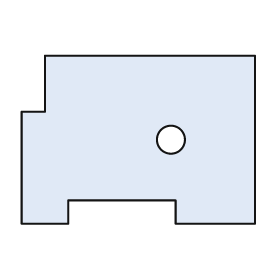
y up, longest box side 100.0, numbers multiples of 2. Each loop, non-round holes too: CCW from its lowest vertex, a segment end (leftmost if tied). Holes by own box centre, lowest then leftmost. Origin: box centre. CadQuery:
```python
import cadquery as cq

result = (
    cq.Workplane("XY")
    .moveTo(-50.0, -36.0)
    .lineTo(-30.0, -36.0)
    .lineTo(-30.0, -26.0)
    .lineTo(16.0, -26.0)
    .lineTo(16.0, -36.0)
    .lineTo(50.0, -36.0)
    .lineTo(50.0, 36.0)
    .lineTo(-40.0, 36.0)
    .lineTo(-40.0, 12.0)
    .lineTo(-50.0, 12.0)
    .close()
    .moveTo(14.0, 0.0)
    .circle(6.0)
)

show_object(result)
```